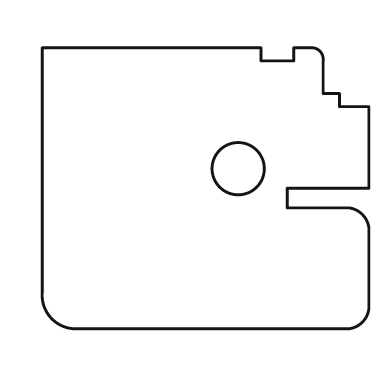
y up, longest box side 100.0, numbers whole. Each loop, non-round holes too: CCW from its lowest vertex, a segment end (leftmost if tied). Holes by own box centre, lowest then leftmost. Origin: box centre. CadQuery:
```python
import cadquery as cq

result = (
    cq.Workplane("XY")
    .moveTo(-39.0, -43.0)
    .lineTo(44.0, -43.0)
    .threePointArc((48.0, -41.0), (50.0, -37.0))
    .lineTo(50.0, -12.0)
    .threePointArc((48.0, -8.0), (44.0, -6.0))
    .lineTo(25.0, -6.0)
    .lineTo(25.0, 0.0)
    .lineTo(50.0, 0.0)
    .lineTo(50.0, 25.0)
    .lineTo(41.0, 25.0)
    .lineTo(41.0, 29.0)
    .lineTo(36.0, 29.0)
    .lineTo(36.0, 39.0)
    .threePointArc((35.0, 42.0), (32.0, 43.0))
    .lineTo(27.0, 43.0)
    .lineTo(27.0, 39.0)
    .lineTo(17.0, 39.0)
    .lineTo(17.0, 43.0)
    .lineTo(-50.0, 43.0)
    .lineTo(-50.0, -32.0)
    .threePointArc((-47.0, -40.0), (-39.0, -43.0))
    .close()
    .moveTo(10.0, 6.0)
    .circle(8.0)
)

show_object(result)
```